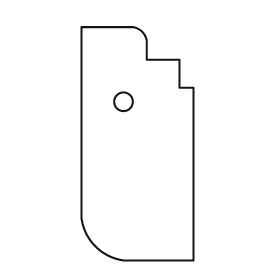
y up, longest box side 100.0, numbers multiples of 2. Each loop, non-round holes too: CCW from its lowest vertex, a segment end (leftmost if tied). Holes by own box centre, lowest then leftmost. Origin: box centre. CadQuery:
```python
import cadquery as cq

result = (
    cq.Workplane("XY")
    .moveTo(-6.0, -50.0)
    .lineTo(24.0, -50.0)
    .lineTo(24.0, 24.0)
    .lineTo(18.0, 24.0)
    .lineTo(18.0, 36.0)
    .lineTo(4.0, 36.0)
    .lineTo(4.0, 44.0)
    .threePointArc((2.0, 48.0), (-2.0, 50.0))
    .lineTo(-24.0, 50.0)
    .lineTo(-24.0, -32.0)
    .threePointArc((-18.0, -44.0), (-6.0, -50.0))
    .close()
    .moveTo(-6.0, 18.0)
    .circle(4.0)
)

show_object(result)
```